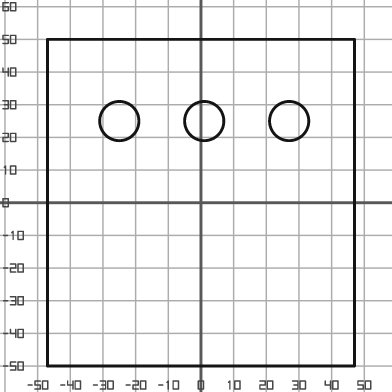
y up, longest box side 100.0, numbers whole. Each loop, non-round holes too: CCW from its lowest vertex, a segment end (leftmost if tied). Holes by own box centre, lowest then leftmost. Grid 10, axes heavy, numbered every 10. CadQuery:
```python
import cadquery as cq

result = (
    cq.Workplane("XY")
    .moveTo(-47.0, -50.0)
    .lineTo(47.0, -50.0)
    .lineTo(47.0, 50.0)
    .lineTo(-47.0, 50.0)
    .close()
    .moveTo(-25.0, 25.0)
    .circle(6.0)
    .moveTo(1.0, 25.0)
    .circle(6.0)
    .moveTo(27.0, 25.0)
    .circle(6.0)
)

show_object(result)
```